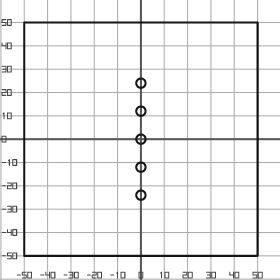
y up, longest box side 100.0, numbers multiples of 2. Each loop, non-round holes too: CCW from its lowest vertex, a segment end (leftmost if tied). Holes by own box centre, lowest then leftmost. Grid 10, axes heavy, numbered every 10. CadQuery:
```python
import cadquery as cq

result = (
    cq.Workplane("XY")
    .moveTo(-50.0, -50.0)
    .lineTo(50.0, -50.0)
    .lineTo(50.0, 50.0)
    .lineTo(-50.0, 50.0)
    .close()
    .moveTo(0.0, -24.0)
    .circle(2.0)
    .moveTo(0.0, -12.0)
    .circle(2.0)
    .moveTo(0.0, 0.0)
    .circle(2.0)
    .moveTo(0.0, 12.0)
    .circle(2.0)
    .moveTo(0.0, 24.0)
    .circle(2.0)
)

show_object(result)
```